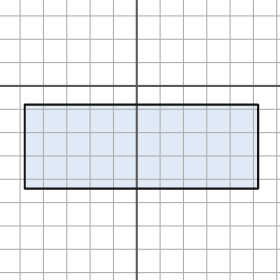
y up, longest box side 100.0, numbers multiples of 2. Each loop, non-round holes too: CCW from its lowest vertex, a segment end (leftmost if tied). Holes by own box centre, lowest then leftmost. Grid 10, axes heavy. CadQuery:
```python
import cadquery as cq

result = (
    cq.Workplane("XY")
    .moveTo(-48.0, -44.0)
    .lineTo(52.0, -44.0)
    .lineTo(52.0, -8.0)
    .lineTo(-48.0, -8.0)
    .close()
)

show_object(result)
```